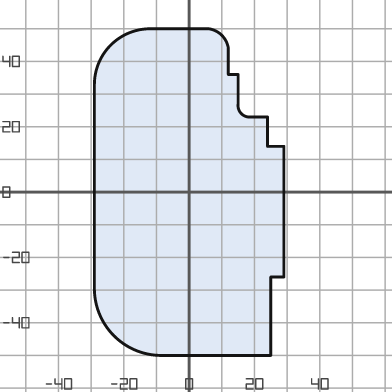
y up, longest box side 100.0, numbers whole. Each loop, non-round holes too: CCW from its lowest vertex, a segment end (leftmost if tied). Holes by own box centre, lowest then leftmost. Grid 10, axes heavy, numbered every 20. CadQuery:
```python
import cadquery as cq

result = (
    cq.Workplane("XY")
    .moveTo(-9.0, -50.0)
    .lineTo(25.0, -50.0)
    .lineTo(25.0, -26.0)
    .lineTo(29.0, -26.0)
    .lineTo(29.0, 14.0)
    .lineTo(24.0, 14.0)
    .lineTo(24.0, 23.0)
    .lineTo(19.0, 23.0)
    .threePointArc((16.0, 24.0), (15.0, 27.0))
    .lineTo(15.0, 36.0)
    .lineTo(12.0, 36.0)
    .lineTo(12.0, 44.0)
    .threePointArc((10.0, 48.0), (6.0, 50.0))
    .lineTo(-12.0, 50.0)
    .threePointArc((-24.0, 45.0), (-29.0, 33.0))
    .lineTo(-29.0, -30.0)
    .threePointArc((-23.0, -44.0), (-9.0, -50.0))
    .close()
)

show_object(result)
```